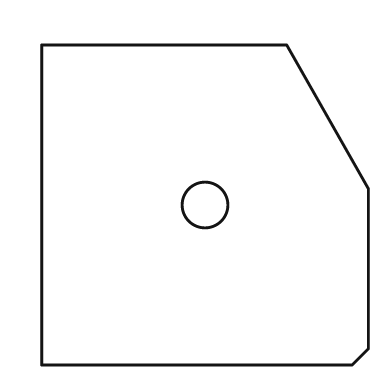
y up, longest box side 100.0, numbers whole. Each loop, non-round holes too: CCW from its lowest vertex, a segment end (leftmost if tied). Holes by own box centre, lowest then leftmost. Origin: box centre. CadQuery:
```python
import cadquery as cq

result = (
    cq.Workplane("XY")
    .moveTo(-50.0, -49.0)
    .lineTo(45.0, -49.0)
    .lineTo(50.0, -44.0)
    .lineTo(50.0, 5.0)
    .lineTo(25.0, 49.0)
    .lineTo(-50.0, 49.0)
    .close()
    .moveTo(0.0, 0.0)
    .circle(7.0)
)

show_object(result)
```